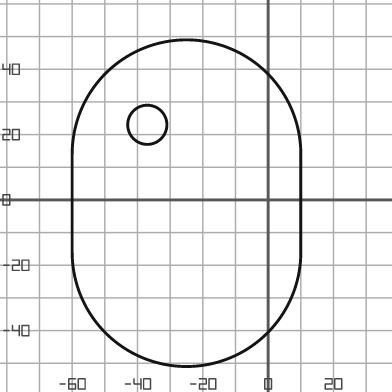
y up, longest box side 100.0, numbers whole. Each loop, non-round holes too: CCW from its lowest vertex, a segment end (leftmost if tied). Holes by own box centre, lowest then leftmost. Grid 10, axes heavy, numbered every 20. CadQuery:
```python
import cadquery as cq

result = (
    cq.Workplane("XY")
    .moveTo(-60.0, -16.0)
    .threePointArc((-25.0, -51.0), (10.0, -16.0))
    .lineTo(10.0, 14.0)
    .threePointArc((-25.0, 49.0), (-60.0, 14.0))
    .close()
    .moveTo(-37.0, 23.0)
    .circle(6.0)
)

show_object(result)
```